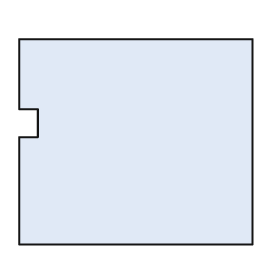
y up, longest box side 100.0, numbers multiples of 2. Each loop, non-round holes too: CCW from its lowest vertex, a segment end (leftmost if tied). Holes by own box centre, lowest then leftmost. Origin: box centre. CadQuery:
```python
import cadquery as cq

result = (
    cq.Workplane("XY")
    .moveTo(-50.0, -44.0)
    .lineTo(50.0, -44.0)
    .lineTo(50.0, 44.0)
    .lineTo(-50.0, 44.0)
    .lineTo(-50.0, 14.0)
    .lineTo(-42.0, 14.0)
    .lineTo(-42.0, 2.0)
    .lineTo(-50.0, 2.0)
    .close()
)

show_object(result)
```